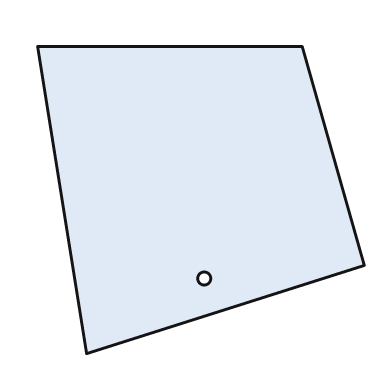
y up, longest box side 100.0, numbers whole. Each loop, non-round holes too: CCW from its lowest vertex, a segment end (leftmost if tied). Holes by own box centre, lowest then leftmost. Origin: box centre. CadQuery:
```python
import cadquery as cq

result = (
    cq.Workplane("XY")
    .moveTo(-35.0, -47.0)
    .lineTo(50.0, -20.0)
    .lineTo(31.0, 47.0)
    .lineTo(-50.0, 47.0)
    .close()
    .moveTo(1.0, -24.0)
    .circle(2.0)
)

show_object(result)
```